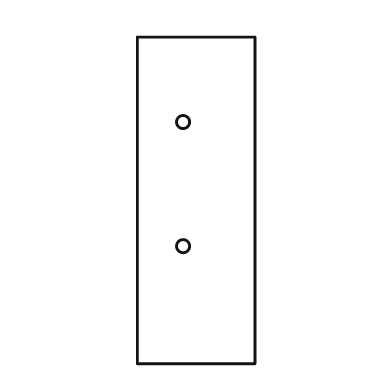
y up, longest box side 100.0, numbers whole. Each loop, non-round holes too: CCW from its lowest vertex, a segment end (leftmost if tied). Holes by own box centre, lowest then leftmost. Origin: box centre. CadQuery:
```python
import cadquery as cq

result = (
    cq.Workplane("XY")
    .moveTo(-18.0, -50.0)
    .lineTo(18.0, -50.0)
    .lineTo(18.0, 50.0)
    .lineTo(-18.0, 50.0)
    .close()
    .moveTo(-4.0, -14.0)
    .circle(2.0)
    .moveTo(-4.0, 24.0)
    .circle(2.0)
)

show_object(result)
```